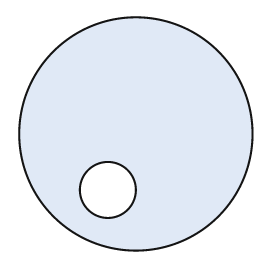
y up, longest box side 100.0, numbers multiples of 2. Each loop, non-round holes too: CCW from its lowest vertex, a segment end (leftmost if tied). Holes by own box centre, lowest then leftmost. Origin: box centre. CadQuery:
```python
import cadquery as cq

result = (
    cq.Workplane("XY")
    .moveTo(0.0, 0.0)
    .circle(50.0)
    .moveTo(-12.0, -24.0)
    .circle(12.0)
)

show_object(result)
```